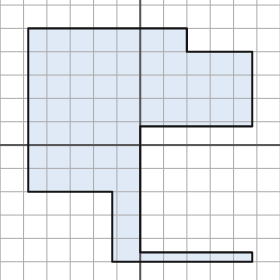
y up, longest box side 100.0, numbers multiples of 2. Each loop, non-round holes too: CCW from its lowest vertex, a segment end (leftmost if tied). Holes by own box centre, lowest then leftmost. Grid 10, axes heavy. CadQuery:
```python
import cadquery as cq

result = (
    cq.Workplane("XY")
    .moveTo(-12.0, -50.0)
    .lineTo(48.0, -50.0)
    .lineTo(48.0, -46.0)
    .lineTo(0.0, -46.0)
    .lineTo(0.0, 8.0)
    .lineTo(48.0, 8.0)
    .lineTo(48.0, 40.0)
    .lineTo(20.0, 40.0)
    .lineTo(20.0, 50.0)
    .lineTo(-48.0, 50.0)
    .lineTo(-48.0, -20.0)
    .lineTo(-12.0, -20.0)
    .close()
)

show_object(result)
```